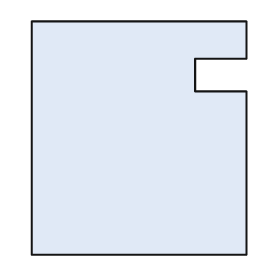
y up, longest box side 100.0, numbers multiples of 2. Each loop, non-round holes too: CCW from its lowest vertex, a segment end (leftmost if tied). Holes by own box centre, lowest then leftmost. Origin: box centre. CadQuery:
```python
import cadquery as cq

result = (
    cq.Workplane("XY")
    .moveTo(-46.0, -50.0)
    .lineTo(46.0, -50.0)
    .lineTo(46.0, 20.0)
    .lineTo(24.0, 20.0)
    .lineTo(24.0, 34.0)
    .lineTo(46.0, 34.0)
    .lineTo(46.0, 50.0)
    .lineTo(-46.0, 50.0)
    .close()
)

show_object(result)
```